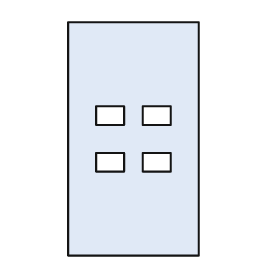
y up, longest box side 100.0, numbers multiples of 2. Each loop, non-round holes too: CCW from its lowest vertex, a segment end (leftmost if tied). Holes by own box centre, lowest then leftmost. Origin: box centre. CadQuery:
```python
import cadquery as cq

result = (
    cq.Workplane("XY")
    .moveTo(-28.0, -50.0)
    .lineTo(28.0, -50.0)
    .lineTo(28.0, 50.0)
    .lineTo(-28.0, 50.0)
    .close()
    .moveTo(-16.0, -14.0)
    .lineTo(-4.0, -14.0)
    .lineTo(-4.0, -6.0)
    .lineTo(-16.0, -6.0)
    .close()
    .moveTo(4.0, -14.0)
    .lineTo(16.0, -14.0)
    .lineTo(16.0, -6.0)
    .lineTo(4.0, -6.0)
    .close()
    .moveTo(-16.0, 6.0)
    .lineTo(-4.0, 6.0)
    .lineTo(-4.0, 14.0)
    .lineTo(-16.0, 14.0)
    .close()
    .moveTo(4.0, 6.0)
    .lineTo(16.0, 6.0)
    .lineTo(16.0, 14.0)
    .lineTo(4.0, 14.0)
    .close()
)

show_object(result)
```